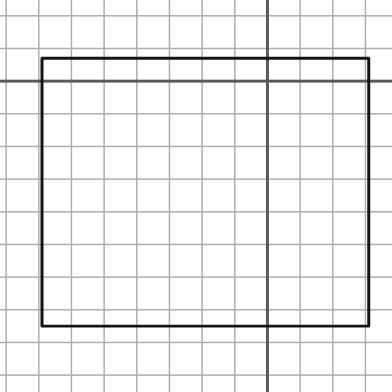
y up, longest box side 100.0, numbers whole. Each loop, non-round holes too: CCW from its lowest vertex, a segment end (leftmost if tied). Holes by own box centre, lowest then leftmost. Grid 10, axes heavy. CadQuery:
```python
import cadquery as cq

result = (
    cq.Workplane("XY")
    .moveTo(-69.0, -75.0)
    .lineTo(31.0, -75.0)
    .lineTo(31.0, 7.0)
    .lineTo(-69.0, 7.0)
    .close()
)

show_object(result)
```